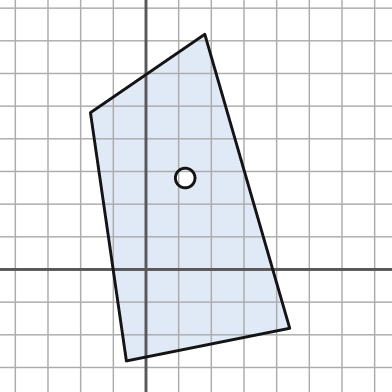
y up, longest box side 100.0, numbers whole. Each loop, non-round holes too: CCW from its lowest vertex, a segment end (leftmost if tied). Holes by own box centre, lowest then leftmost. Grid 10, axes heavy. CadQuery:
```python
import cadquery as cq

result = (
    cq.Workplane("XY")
    .moveTo(-6.0, -28.0)
    .lineTo(44.0, -18.0)
    .lineTo(18.0, 72.0)
    .lineTo(-17.0, 48.0)
    .close()
    .moveTo(12.0, 28.0)
    .circle(3.0)
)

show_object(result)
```